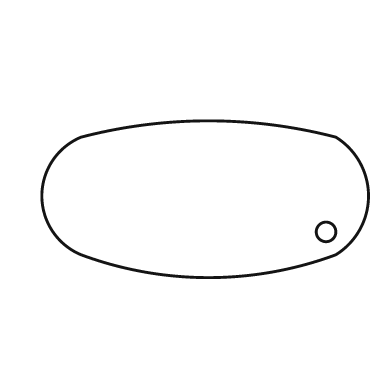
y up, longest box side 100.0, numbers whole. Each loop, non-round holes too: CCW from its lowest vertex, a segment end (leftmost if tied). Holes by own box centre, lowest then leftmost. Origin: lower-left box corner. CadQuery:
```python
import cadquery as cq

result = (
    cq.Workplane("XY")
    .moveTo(12.0, 7.0)
    .threePointArc((51.0, 0.0), (90.0, 7.0))
    .threePointArc((100.0, 25.0), (90.0, 43.0))
    .threePointArc((51.0, 48.0), (12.0, 43.0))
    .threePointArc((0.0, 25.0), (12.0, 7.0))
    .close()
    .moveTo(87.0, 14.0)
    .circle(3.0)
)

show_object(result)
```